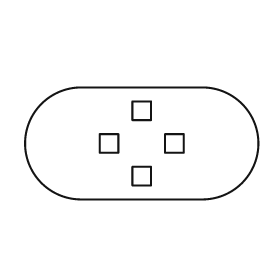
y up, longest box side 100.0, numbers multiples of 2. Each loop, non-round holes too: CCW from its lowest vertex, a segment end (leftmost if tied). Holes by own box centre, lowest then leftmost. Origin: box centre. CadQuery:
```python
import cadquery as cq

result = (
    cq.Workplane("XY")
    .moveTo(-26.0, -24.0)
    .lineTo(26.0, -24.0)
    .threePointArc((50.0, 0.0), (26.0, 24.0))
    .lineTo(-26.0, 24.0)
    .threePointArc((-50.0, 0.0), (-26.0, -24.0))
    .close()
    .moveTo(-4.0, -18.0)
    .lineTo(4.0, -18.0)
    .lineTo(4.0, -10.0)
    .lineTo(-4.0, -10.0)
    .close()
    .moveTo(-18.0, -4.0)
    .lineTo(-10.0, -4.0)
    .lineTo(-10.0, 4.0)
    .lineTo(-18.0, 4.0)
    .close()
    .moveTo(10.0, -4.0)
    .lineTo(18.0, -4.0)
    .lineTo(18.0, 4.0)
    .lineTo(10.0, 4.0)
    .close()
    .moveTo(-4.0, 10.0)
    .lineTo(4.0, 10.0)
    .lineTo(4.0, 18.0)
    .lineTo(-4.0, 18.0)
    .close()
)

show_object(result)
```